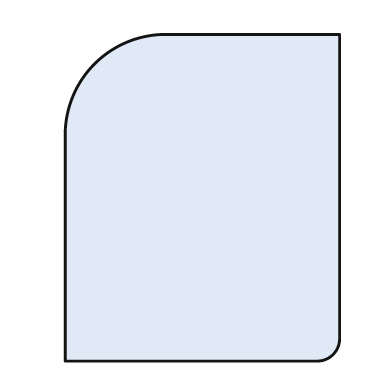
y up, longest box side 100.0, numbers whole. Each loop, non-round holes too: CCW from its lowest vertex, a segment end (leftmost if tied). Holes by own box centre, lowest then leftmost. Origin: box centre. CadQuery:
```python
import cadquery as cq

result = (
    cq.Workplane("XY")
    .moveTo(-42.0, -50.0)
    .lineTo(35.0, -50.0)
    .threePointArc((40.0, -48.0), (42.0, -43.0))
    .lineTo(42.0, 50.0)
    .lineTo(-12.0, 50.0)
    .threePointArc((-33.0, 41.0), (-42.0, 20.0))
    .close()
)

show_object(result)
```